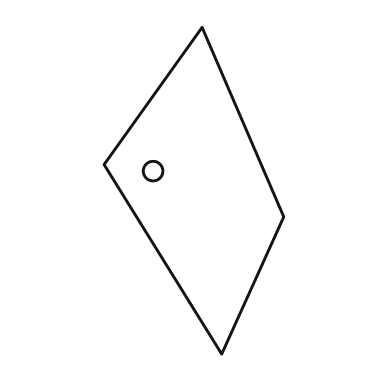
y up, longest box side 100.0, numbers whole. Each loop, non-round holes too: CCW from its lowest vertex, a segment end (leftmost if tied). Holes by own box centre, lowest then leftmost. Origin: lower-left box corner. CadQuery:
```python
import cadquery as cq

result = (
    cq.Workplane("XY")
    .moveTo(36.0, 0.0)
    .lineTo(55.0, 42.0)
    .lineTo(30.0, 100.0)
    .lineTo(0.0, 58.0)
    .close()
    .moveTo(15.0, 56.0)
    .circle(3.0)
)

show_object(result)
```